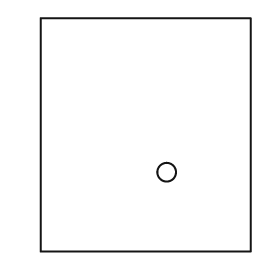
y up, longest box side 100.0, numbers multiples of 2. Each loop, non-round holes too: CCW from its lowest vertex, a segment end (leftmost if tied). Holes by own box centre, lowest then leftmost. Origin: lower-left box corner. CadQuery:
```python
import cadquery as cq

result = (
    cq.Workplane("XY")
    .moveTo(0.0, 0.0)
    .lineTo(90.0, 0.0)
    .lineTo(90.0, 100.0)
    .lineTo(0.0, 100.0)
    .close()
    .moveTo(54.0, 34.0)
    .circle(4.0)
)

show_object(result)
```